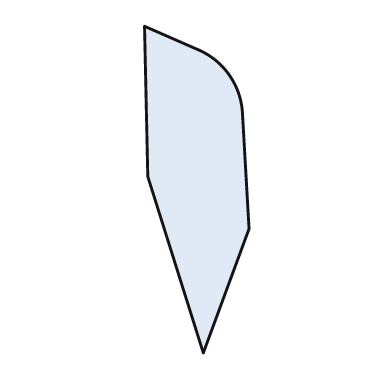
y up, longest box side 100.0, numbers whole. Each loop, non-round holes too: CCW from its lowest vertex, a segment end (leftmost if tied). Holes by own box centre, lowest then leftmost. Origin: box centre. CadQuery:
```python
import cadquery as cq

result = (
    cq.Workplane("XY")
    .moveTo(2.0, -50.0)
    .lineTo(16.0, -12.0)
    .lineTo(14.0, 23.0)
    .threePointArc((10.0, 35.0), (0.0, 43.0))
    .lineTo(-16.0, 50.0)
    .lineTo(-15.0, 4.0)
    .close()
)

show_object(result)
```